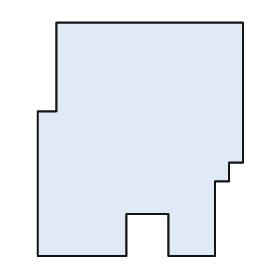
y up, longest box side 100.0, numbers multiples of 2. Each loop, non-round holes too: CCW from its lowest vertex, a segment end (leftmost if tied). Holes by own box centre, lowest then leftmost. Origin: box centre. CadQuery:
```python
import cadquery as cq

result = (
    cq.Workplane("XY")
    .moveTo(-44.0, -50.0)
    .lineTo(-6.0, -50.0)
    .lineTo(-6.0, -32.0)
    .lineTo(12.0, -32.0)
    .lineTo(12.0, -50.0)
    .lineTo(32.0, -50.0)
    .lineTo(32.0, -18.0)
    .lineTo(38.0, -18.0)
    .lineTo(38.0, -10.0)
    .lineTo(44.0, -10.0)
    .lineTo(44.0, 50.0)
    .lineTo(-36.0, 50.0)
    .lineTo(-36.0, 12.0)
    .lineTo(-44.0, 12.0)
    .close()
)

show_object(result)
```